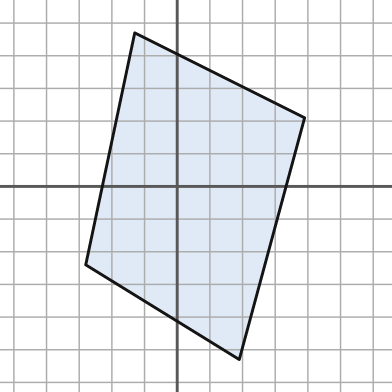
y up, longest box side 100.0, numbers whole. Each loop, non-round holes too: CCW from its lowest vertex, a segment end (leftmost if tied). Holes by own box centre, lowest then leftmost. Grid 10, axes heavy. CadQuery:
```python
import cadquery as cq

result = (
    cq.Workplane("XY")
    .moveTo(19.0, -53.0)
    .lineTo(39.0, 21.0)
    .lineTo(-13.0, 47.0)
    .lineTo(-28.0, -24.0)
    .close()
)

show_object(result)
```